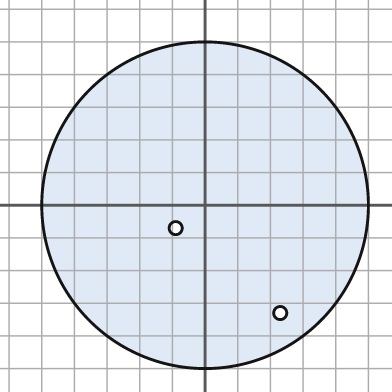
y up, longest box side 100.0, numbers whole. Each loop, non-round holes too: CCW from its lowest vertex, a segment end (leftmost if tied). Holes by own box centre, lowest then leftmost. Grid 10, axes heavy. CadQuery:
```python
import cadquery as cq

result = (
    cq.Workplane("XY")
    .moveTo(0.0, 0.0)
    .circle(50.0)
    .moveTo(23.0, -33.0)
    .circle(2.0)
    .moveTo(-9.0, -7.0)
    .circle(2.0)
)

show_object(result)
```